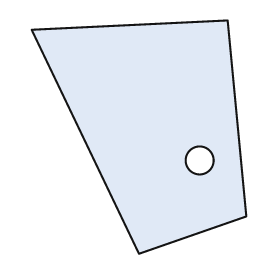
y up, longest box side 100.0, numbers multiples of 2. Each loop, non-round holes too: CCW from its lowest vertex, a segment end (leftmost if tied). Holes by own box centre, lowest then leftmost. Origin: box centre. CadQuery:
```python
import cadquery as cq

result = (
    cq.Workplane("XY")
    .moveTo(0.0, -50.0)
    .lineTo(46.0, -34.0)
    .lineTo(38.0, 50.0)
    .lineTo(-46.0, 46.0)
    .close()
    .moveTo(26.0, -10.0)
    .circle(6.0)
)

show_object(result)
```